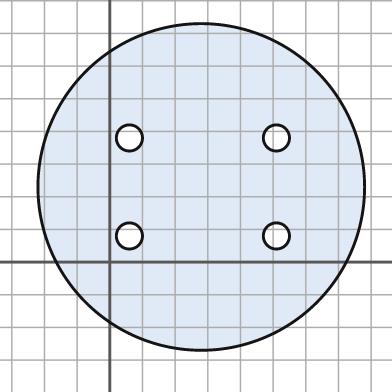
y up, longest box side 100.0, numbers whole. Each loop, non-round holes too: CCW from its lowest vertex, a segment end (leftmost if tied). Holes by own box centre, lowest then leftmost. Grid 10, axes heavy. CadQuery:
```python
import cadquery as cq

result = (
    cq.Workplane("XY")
    .moveTo(28.0, 23.0)
    .circle(50.0)
    .moveTo(6.0, 8.0)
    .circle(4.0)
    .moveTo(51.0, 8.0)
    .circle(4.0)
    .moveTo(6.0, 38.0)
    .circle(4.0)
    .moveTo(51.0, 38.0)
    .circle(4.0)
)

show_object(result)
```